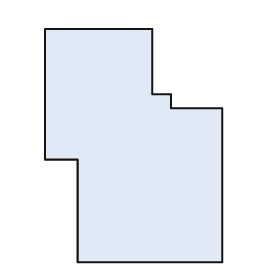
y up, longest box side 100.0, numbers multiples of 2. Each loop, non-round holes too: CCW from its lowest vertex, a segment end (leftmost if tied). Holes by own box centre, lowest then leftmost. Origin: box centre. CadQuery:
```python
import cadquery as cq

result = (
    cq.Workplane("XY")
    .moveTo(-24.0, -50.0)
    .lineTo(38.0, -50.0)
    .lineTo(38.0, 16.0)
    .lineTo(16.0, 16.0)
    .lineTo(16.0, 22.0)
    .lineTo(8.0, 22.0)
    .lineTo(8.0, 50.0)
    .lineTo(-38.0, 50.0)
    .lineTo(-38.0, -6.0)
    .lineTo(-24.0, -6.0)
    .close()
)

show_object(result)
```